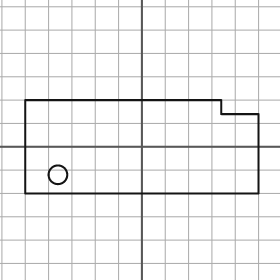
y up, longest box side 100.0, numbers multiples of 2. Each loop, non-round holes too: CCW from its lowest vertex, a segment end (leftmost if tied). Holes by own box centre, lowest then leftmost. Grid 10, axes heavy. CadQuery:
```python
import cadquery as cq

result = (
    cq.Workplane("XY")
    .moveTo(-50.0, -20.0)
    .lineTo(50.0, -20.0)
    .lineTo(50.0, 14.0)
    .lineTo(34.0, 14.0)
    .lineTo(34.0, 20.0)
    .lineTo(-50.0, 20.0)
    .close()
    .moveTo(-36.0, -12.0)
    .circle(4.0)
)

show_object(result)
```